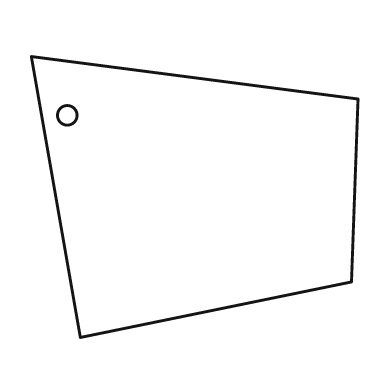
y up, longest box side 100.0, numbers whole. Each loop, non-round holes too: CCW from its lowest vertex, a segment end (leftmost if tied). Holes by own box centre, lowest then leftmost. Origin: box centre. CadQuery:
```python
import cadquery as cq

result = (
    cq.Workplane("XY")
    .moveTo(-35.0, -43.0)
    .lineTo(48.0, -26.0)
    .lineTo(50.0, 30.0)
    .lineTo(-50.0, 43.0)
    .close()
    .moveTo(-39.0, 25.0)
    .circle(3.0)
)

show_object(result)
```